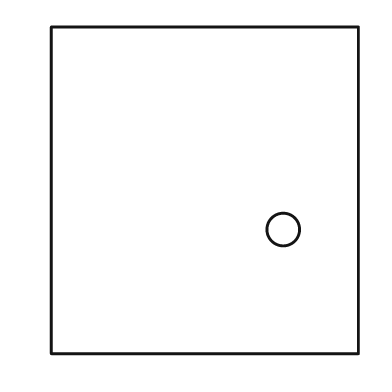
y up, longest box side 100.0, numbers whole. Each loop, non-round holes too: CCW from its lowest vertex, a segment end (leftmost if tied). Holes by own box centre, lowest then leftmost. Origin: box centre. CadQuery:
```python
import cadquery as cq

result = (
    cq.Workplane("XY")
    .moveTo(-47.0, -50.0)
    .lineTo(47.0, -50.0)
    .lineTo(47.0, 50.0)
    .lineTo(-47.0, 50.0)
    .close()
    .moveTo(24.0, -12.0)
    .circle(5.0)
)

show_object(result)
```